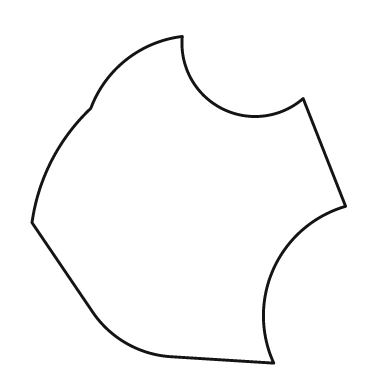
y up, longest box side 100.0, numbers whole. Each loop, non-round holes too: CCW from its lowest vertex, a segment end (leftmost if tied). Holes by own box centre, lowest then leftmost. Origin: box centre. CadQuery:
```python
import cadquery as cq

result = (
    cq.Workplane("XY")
    .moveTo(26.0, -50.0)
    .threePointArc((26.0, -21.0), (48.0, -2.0))
    .lineTo(35.0, 31.0)
    .threePointArc((10.0, 28.0), (-2.0, 50.0))
    .threePointArc((-19.0, 43.0), (-30.0, 28.0))
    .threePointArc((-42.0, 12.0), (-48.0, -7.0))
    .lineTo(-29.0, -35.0)
    .threePointArc((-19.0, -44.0), (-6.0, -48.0))
    .close()
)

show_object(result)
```